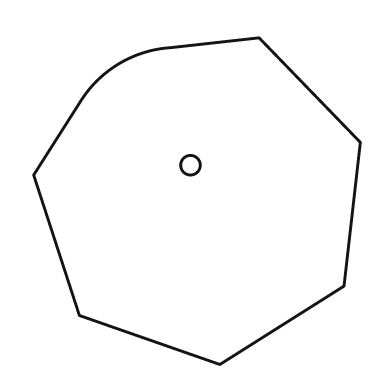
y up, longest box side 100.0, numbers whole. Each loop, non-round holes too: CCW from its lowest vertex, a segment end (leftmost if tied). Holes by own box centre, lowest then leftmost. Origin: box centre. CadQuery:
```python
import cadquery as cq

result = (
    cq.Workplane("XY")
    .moveTo(7.0, -50.0)
    .lineTo(45.0, -26.0)
    .lineTo(50.0, 18.0)
    .lineTo(19.0, 50.0)
    .lineTo(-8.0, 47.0)
    .threePointArc((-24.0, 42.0), (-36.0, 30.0))
    .lineTo(-50.0, 8.0)
    .lineTo(-36.0, -35.0)
    .close()
    .moveTo(-2.0, 11.0)
    .circle(3.0)
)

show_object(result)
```